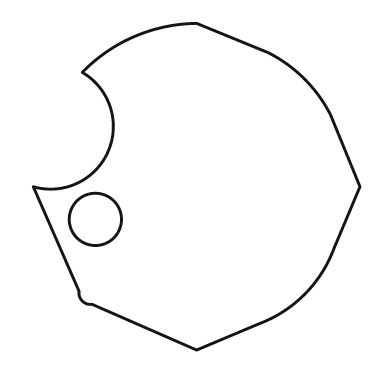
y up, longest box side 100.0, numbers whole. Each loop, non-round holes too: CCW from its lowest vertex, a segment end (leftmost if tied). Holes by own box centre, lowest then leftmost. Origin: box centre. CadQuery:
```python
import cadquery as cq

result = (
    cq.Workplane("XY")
    .moveTo(0.0, -50.0)
    .lineTo(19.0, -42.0)
    .threePointArc((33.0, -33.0), (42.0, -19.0))
    .lineTo(50.0, 0.0)
    .lineTo(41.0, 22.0)
    .threePointArc((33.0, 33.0), (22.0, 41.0))
    .lineTo(0.0, 50.0)
    .threePointArc((-19.0, 46.0), (-35.0, 35.0))
    .threePointArc((-27.0, 11.0), (-50.0, 0.0))
    .lineTo(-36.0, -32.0)
    .threePointArc((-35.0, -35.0), (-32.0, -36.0))
    .close()
    .moveTo(-31.0, -10.0)
    .circle(8.0)
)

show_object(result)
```